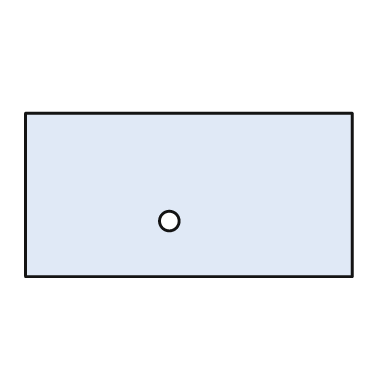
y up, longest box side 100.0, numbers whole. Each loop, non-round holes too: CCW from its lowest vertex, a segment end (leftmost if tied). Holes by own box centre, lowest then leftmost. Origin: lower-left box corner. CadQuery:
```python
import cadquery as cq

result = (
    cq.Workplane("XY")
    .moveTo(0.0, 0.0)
    .lineTo(100.0, 0.0)
    .lineTo(100.0, 50.0)
    .lineTo(0.0, 50.0)
    .close()
    .moveTo(44.0, 17.0)
    .circle(3.0)
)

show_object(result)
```